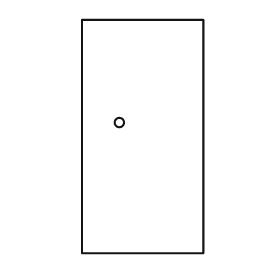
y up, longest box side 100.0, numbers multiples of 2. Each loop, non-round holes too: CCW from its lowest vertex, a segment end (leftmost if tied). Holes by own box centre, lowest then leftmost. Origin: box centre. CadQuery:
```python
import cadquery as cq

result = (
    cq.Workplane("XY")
    .moveTo(-26.0, -50.0)
    .lineTo(26.0, -50.0)
    .lineTo(26.0, 50.0)
    .lineTo(-26.0, 50.0)
    .close()
    .moveTo(-10.0, 6.0)
    .circle(2.0)
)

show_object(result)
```